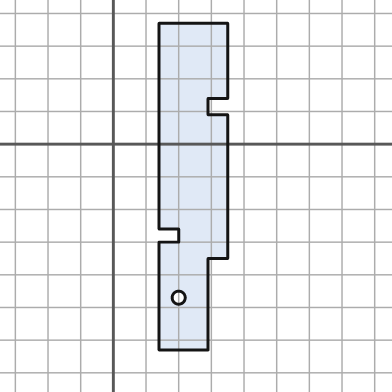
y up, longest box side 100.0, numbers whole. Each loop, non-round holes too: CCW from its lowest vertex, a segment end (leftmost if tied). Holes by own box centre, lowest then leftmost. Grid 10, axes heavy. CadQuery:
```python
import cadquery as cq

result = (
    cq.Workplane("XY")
    .moveTo(14.0, -63.0)
    .lineTo(29.0, -63.0)
    .lineTo(29.0, -35.0)
    .lineTo(35.0, -35.0)
    .lineTo(35.0, 9.0)
    .lineTo(29.0, 9.0)
    .lineTo(29.0, 14.0)
    .lineTo(35.0, 14.0)
    .lineTo(35.0, 37.0)
    .lineTo(14.0, 37.0)
    .lineTo(14.0, -26.0)
    .lineTo(20.0, -26.0)
    .lineTo(20.0, -30.0)
    .lineTo(14.0, -30.0)
    .close()
    .moveTo(20.0, -47.0)
    .circle(2.0)
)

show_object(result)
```